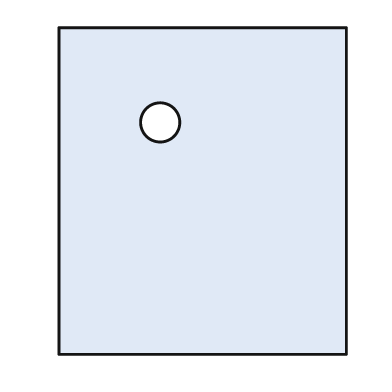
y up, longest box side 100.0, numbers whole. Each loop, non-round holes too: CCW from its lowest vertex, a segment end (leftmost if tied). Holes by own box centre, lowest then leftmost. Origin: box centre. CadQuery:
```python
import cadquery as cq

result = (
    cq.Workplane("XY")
    .moveTo(-44.0, -50.0)
    .lineTo(44.0, -50.0)
    .lineTo(44.0, 50.0)
    .lineTo(-44.0, 50.0)
    .close()
    .moveTo(-13.0, 21.0)
    .circle(6.0)
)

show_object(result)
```